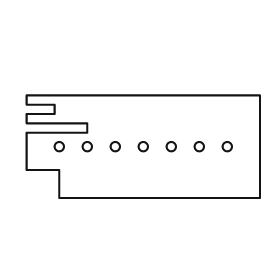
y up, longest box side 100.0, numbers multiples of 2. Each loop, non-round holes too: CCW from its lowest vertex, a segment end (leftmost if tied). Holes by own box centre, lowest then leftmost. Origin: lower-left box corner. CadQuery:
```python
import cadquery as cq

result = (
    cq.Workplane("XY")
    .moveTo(14.0, 0.0)
    .lineTo(100.0, 0.0)
    .lineTo(100.0, 44.0)
    .lineTo(0.0, 44.0)
    .lineTo(0.0, 40.0)
    .lineTo(12.0, 40.0)
    .lineTo(12.0, 36.0)
    .lineTo(0.0, 36.0)
    .lineTo(0.0, 32.0)
    .lineTo(26.0, 32.0)
    .lineTo(26.0, 28.0)
    .lineTo(0.0, 28.0)
    .lineTo(0.0, 12.0)
    .lineTo(14.0, 12.0)
    .close()
    .moveTo(14.0, 22.0)
    .circle(2.0)
    .moveTo(26.0, 22.0)
    .circle(2.0)
    .moveTo(38.0, 22.0)
    .circle(2.0)
    .moveTo(50.0, 22.0)
    .circle(2.0)
    .moveTo(62.0, 22.0)
    .circle(2.0)
    .moveTo(74.0, 22.0)
    .circle(2.0)
    .moveTo(86.0, 22.0)
    .circle(2.0)
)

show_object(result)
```